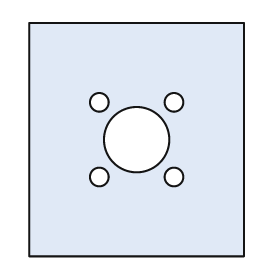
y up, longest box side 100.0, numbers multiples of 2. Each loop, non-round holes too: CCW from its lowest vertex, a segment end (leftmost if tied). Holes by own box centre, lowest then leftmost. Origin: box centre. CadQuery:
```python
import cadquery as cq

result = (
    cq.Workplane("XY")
    .moveTo(-46.0, -50.0)
    .lineTo(46.0, -50.0)
    .lineTo(46.0, 50.0)
    .lineTo(-46.0, 50.0)
    .close()
    .moveTo(-16.0, -16.0)
    .circle(4.0)
    .moveTo(16.0, -16.0)
    .circle(4.0)
    .moveTo(0.0, 0.0)
    .circle(14.0)
    .moveTo(-16.0, 16.0)
    .circle(4.0)
    .moveTo(16.0, 16.0)
    .circle(4.0)
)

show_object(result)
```